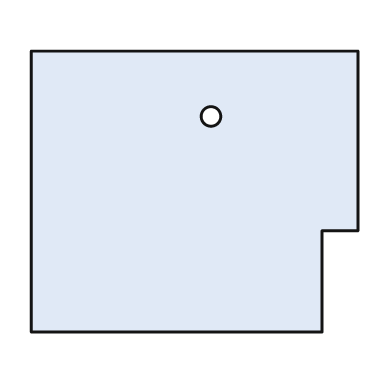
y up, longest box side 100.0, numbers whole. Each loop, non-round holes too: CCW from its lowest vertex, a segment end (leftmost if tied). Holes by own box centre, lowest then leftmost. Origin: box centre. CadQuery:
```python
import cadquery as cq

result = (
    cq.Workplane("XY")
    .moveTo(-50.0, -43.0)
    .lineTo(39.0, -43.0)
    .lineTo(39.0, -12.0)
    .lineTo(50.0, -12.0)
    .lineTo(50.0, 43.0)
    .lineTo(-50.0, 43.0)
    .close()
    .moveTo(5.0, 23.0)
    .circle(3.0)
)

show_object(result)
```